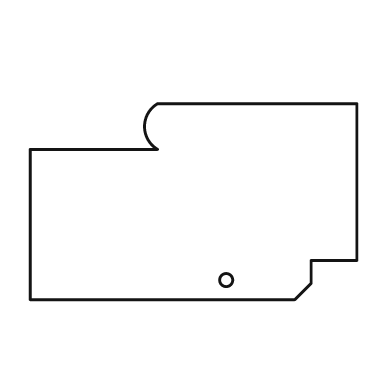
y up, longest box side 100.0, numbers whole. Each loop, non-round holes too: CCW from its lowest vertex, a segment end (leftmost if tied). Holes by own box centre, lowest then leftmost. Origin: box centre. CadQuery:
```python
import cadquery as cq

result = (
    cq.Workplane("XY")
    .moveTo(-50.0, -30.0)
    .lineTo(31.0, -30.0)
    .lineTo(36.0, -25.0)
    .lineTo(36.0, -18.0)
    .lineTo(50.0, -18.0)
    .lineTo(50.0, 30.0)
    .lineTo(-11.0, 30.0)
    .threePointArc((-15.0, 23.0), (-11.0, 16.0))
    .lineTo(-50.0, 16.0)
    .close()
    .moveTo(10.0, -24.0)
    .circle(2.0)
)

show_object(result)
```